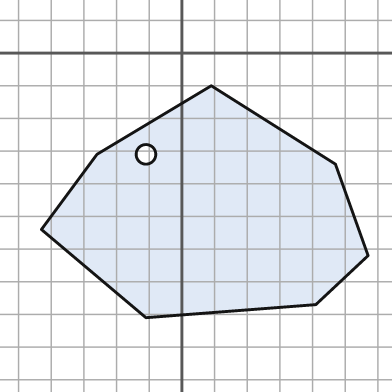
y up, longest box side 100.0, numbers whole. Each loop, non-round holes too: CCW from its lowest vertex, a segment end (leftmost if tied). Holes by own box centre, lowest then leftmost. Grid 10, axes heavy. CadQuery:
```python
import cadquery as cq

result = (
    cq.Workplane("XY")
    .moveTo(-11.0, -81.0)
    .lineTo(41.0, -77.0)
    .lineTo(57.0, -62.0)
    .lineTo(47.0, -34.0)
    .lineTo(9.0, -10.0)
    .lineTo(-26.0, -31.0)
    .lineTo(-43.0, -54.0)
    .close()
    .moveTo(-11.0, -31.0)
    .circle(3.0)
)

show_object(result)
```